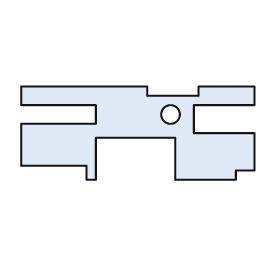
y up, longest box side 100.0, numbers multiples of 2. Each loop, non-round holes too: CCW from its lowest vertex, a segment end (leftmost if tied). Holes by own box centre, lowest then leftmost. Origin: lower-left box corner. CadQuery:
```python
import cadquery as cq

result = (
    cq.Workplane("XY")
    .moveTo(28.0, 0.0)
    .lineTo(32.0, 0.0)
    .lineTo(32.0, 18.0)
    .lineTo(66.0, 18.0)
    .lineTo(66.0, 0.0)
    .lineTo(92.0, 0.0)
    .lineTo(92.0, 4.0)
    .lineTo(100.0, 4.0)
    .lineTo(100.0, 20.0)
    .lineTo(74.0, 20.0)
    .lineTo(74.0, 32.0)
    .lineTo(100.0, 32.0)
    .lineTo(100.0, 40.0)
    .lineTo(76.0, 40.0)
    .lineTo(76.0, 36.0)
    .lineTo(54.0, 36.0)
    .lineTo(54.0, 40.0)
    .lineTo(0.0, 40.0)
    .lineTo(0.0, 32.0)
    .lineTo(32.0, 32.0)
    .lineTo(32.0, 24.0)
    .lineTo(0.0, 24.0)
    .lineTo(0.0, 6.0)
    .lineTo(28.0, 6.0)
    .close()
    .moveTo(64.0, 28.0)
    .circle(4.0)
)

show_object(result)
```